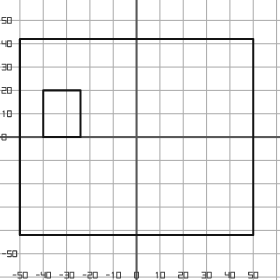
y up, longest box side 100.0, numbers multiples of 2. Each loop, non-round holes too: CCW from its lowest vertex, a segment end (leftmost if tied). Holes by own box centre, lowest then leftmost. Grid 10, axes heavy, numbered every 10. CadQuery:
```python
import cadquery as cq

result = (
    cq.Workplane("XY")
    .moveTo(-50.0, -42.0)
    .lineTo(50.0, -42.0)
    .lineTo(50.0, 42.0)
    .lineTo(-50.0, 42.0)
    .close()
    .moveTo(-40.0, 0.0)
    .lineTo(-24.0, 0.0)
    .lineTo(-24.0, 20.0)
    .lineTo(-40.0, 20.0)
    .close()
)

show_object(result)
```